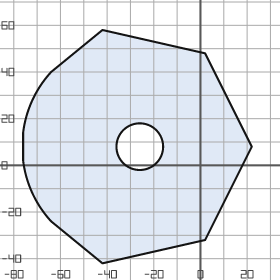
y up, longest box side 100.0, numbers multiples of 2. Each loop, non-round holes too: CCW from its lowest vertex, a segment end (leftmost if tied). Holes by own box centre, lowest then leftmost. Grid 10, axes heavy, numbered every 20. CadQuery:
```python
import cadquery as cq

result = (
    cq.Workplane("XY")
    .moveTo(-42.0, -42.0)
    .lineTo(2.0, -32.0)
    .lineTo(22.0, 8.0)
    .lineTo(2.0, 48.0)
    .lineTo(-42.0, 58.0)
    .lineTo(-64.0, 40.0)
    .threePointArc((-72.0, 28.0), (-76.0, 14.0))
    .lineTo(-76.0, 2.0)
    .threePointArc((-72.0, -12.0), (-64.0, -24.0))
    .close()
    .moveTo(-26.0, 8.0)
    .circle(10.0)
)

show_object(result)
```